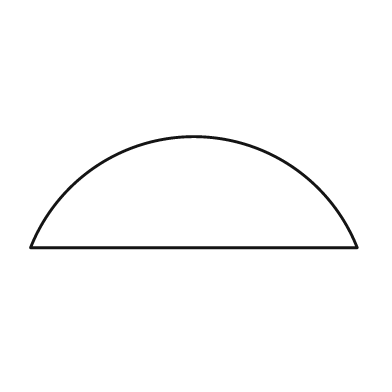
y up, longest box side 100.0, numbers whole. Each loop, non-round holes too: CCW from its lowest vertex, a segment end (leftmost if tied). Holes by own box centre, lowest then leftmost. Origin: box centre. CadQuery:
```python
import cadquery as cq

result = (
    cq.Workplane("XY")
    .moveTo(-50.0, -17.0)
    .lineTo(50.0, -17.0)
    .threePointArc((0.0, 17.0), (-50.0, -17.0))
    .close()
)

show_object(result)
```